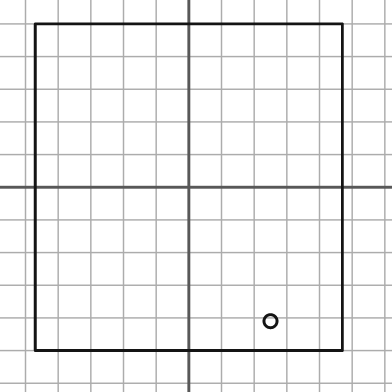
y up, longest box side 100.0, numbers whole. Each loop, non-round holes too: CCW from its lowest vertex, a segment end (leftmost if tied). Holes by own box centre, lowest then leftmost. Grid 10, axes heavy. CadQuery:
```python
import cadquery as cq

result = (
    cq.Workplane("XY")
    .moveTo(-47.0, -50.0)
    .lineTo(47.0, -50.0)
    .lineTo(47.0, 50.0)
    .lineTo(-47.0, 50.0)
    .close()
    .moveTo(25.0, -41.0)
    .circle(2.0)
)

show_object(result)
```